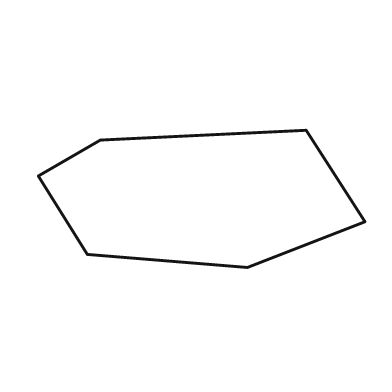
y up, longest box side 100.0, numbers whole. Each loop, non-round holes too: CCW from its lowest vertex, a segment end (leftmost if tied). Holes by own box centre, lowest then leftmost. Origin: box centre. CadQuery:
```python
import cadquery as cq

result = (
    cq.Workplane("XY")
    .moveTo(14.0, -21.0)
    .lineTo(50.0, -7.0)
    .lineTo(32.0, 21.0)
    .lineTo(-31.0, 18.0)
    .lineTo(-50.0, 7.0)
    .lineTo(-35.0, -17.0)
    .close()
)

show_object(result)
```